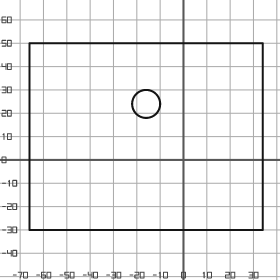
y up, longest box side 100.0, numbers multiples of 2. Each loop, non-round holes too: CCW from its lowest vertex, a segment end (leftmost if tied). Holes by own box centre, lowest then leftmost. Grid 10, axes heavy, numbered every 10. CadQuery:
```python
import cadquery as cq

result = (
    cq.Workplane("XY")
    .moveTo(-66.0, -30.0)
    .lineTo(34.0, -30.0)
    .lineTo(34.0, 50.0)
    .lineTo(-66.0, 50.0)
    .close()
    .moveTo(-16.0, 24.0)
    .circle(6.0)
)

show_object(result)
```